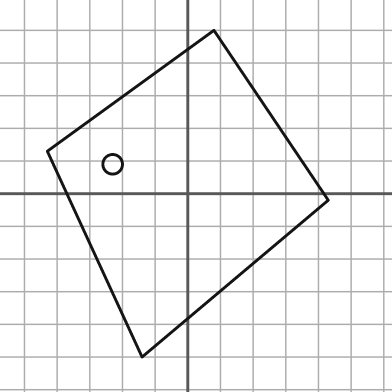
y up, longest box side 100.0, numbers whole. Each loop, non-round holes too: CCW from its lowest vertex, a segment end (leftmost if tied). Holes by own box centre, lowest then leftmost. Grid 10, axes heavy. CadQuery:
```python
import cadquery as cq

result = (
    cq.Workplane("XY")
    .moveTo(-14.0, -50.0)
    .lineTo(43.0, -2.0)
    .lineTo(8.0, 50.0)
    .lineTo(-43.0, 13.0)
    .close()
    .moveTo(-23.0, 9.0)
    .circle(3.0)
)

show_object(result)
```